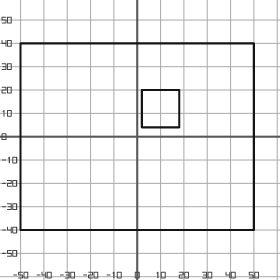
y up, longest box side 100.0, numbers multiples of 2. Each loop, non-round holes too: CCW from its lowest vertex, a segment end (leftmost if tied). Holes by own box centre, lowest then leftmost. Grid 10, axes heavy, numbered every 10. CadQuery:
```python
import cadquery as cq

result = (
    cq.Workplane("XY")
    .moveTo(-50.0, -40.0)
    .lineTo(50.0, -40.0)
    .lineTo(50.0, 40.0)
    .lineTo(-50.0, 40.0)
    .close()
    .moveTo(2.0, 4.0)
    .lineTo(18.0, 4.0)
    .lineTo(18.0, 20.0)
    .lineTo(2.0, 20.0)
    .close()
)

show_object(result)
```